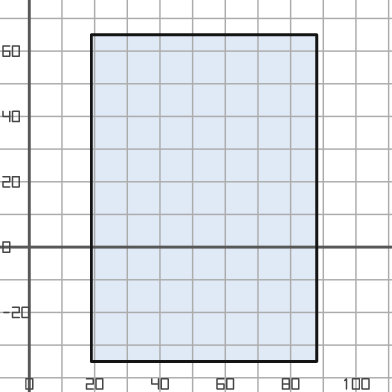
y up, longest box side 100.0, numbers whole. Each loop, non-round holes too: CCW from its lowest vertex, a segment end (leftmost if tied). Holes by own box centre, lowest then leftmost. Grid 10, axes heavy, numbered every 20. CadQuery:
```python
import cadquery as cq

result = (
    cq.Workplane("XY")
    .moveTo(19.0, -35.0)
    .lineTo(88.0, -35.0)
    .lineTo(88.0, 65.0)
    .lineTo(19.0, 65.0)
    .close()
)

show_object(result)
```